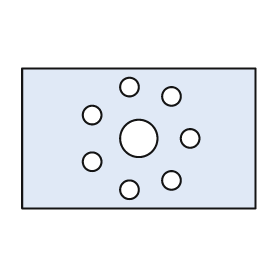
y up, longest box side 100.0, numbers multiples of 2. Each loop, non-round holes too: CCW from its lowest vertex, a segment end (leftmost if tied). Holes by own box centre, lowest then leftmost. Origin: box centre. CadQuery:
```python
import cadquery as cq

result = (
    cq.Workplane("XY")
    .moveTo(-50.0, -30.0)
    .lineTo(50.0, -30.0)
    .lineTo(50.0, 30.0)
    .lineTo(-50.0, 30.0)
    .close()
    .moveTo(-4.0, -22.0)
    .circle(4.0)
    .moveTo(14.0, -18.0)
    .circle(4.0)
    .moveTo(-20.0, -10.0)
    .circle(4.0)
    .moveTo(0.0, 0.0)
    .circle(8.0)
    .moveTo(22.0, 0.0)
    .circle(4.0)
    .moveTo(-20.0, 10.0)
    .circle(4.0)
    .moveTo(14.0, 18.0)
    .circle(4.0)
    .moveTo(-4.0, 22.0)
    .circle(4.0)
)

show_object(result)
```